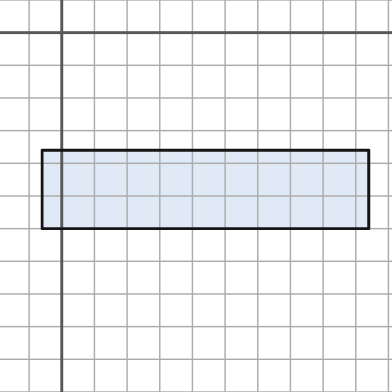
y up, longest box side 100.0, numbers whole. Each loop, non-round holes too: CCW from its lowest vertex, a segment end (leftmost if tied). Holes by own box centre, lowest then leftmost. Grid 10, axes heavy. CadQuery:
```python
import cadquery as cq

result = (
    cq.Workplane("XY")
    .moveTo(-6.0, -60.0)
    .lineTo(94.0, -60.0)
    .lineTo(94.0, -36.0)
    .lineTo(-6.0, -36.0)
    .close()
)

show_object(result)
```